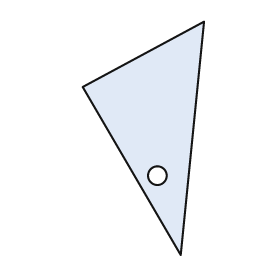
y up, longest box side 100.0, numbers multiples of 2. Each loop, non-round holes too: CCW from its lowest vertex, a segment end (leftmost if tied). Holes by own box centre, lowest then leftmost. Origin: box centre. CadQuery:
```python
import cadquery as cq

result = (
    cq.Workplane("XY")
    .moveTo(16.0, -50.0)
    .lineTo(26.0, 50.0)
    .lineTo(-26.0, 22.0)
    .close()
    .moveTo(6.0, -16.0)
    .circle(4.0)
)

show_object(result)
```